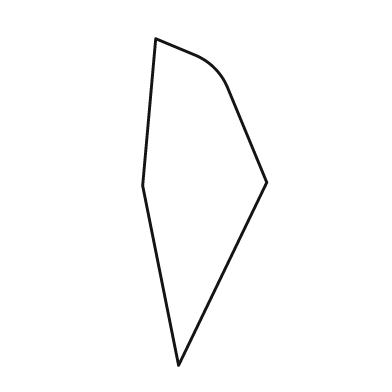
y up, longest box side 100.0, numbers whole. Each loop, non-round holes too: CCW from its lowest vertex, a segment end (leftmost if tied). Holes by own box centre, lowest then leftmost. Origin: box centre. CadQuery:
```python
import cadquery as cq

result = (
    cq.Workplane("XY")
    .moveTo(-8.0, -50.0)
    .lineTo(19.0, 6.0)
    .lineTo(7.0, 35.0)
    .threePointArc((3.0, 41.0), (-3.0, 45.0))
    .lineTo(-15.0, 50.0)
    .lineTo(-19.0, 5.0)
    .close()
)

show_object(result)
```